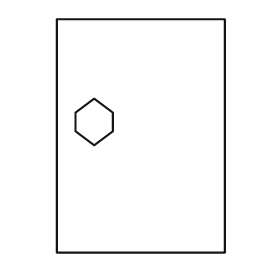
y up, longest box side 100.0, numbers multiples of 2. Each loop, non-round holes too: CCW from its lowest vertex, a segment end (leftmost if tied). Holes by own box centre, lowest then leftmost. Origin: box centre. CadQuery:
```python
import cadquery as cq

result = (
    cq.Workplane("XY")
    .moveTo(-36.0, -50.0)
    .lineTo(36.0, -50.0)
    .lineTo(36.0, 50.0)
    .lineTo(-36.0, 50.0)
    .close()
    .moveTo(-20.0, -4.0)
    .lineTo(-12.0, 2.0)
    .lineTo(-12.0, 10.0)
    .lineTo(-20.0, 16.0)
    .lineTo(-28.0, 10.0)
    .lineTo(-28.0, 2.0)
    .close()
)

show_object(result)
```